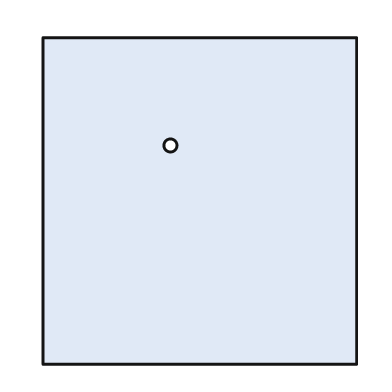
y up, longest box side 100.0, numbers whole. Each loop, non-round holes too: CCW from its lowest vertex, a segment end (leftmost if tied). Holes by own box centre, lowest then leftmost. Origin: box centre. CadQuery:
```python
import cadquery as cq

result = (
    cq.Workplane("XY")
    .moveTo(-48.0, -50.0)
    .lineTo(48.0, -50.0)
    .lineTo(48.0, 50.0)
    .lineTo(-48.0, 50.0)
    .close()
    .moveTo(-9.0, 17.0)
    .circle(2.0)
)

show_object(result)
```